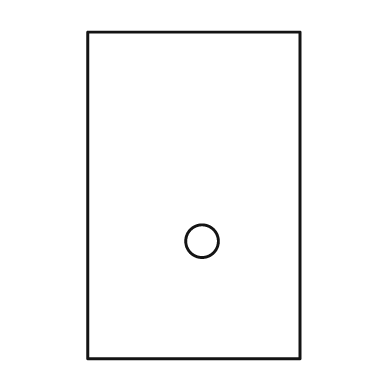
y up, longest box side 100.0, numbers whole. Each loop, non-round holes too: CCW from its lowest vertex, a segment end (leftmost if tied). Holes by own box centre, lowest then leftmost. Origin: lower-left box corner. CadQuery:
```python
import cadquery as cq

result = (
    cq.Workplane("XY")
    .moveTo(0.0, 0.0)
    .lineTo(65.0, 0.0)
    .lineTo(65.0, 100.0)
    .lineTo(0.0, 100.0)
    .close()
    .moveTo(35.0, 36.0)
    .circle(5.0)
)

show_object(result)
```